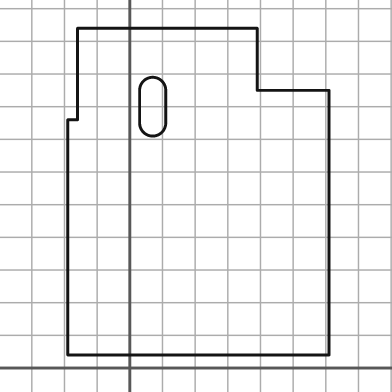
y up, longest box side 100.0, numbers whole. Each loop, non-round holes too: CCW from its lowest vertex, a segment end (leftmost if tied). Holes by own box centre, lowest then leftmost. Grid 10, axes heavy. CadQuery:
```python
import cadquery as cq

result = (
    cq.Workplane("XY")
    .moveTo(-19.0, 4.0)
    .lineTo(61.0, 4.0)
    .lineTo(61.0, 85.0)
    .lineTo(39.0, 85.0)
    .lineTo(39.0, 104.0)
    .lineTo(-16.0, 104.0)
    .lineTo(-16.0, 76.0)
    .lineTo(-19.0, 76.0)
    .close()
    .moveTo(3.0, 75.0)
    .threePointArc((7.0, 71.0), (11.0, 75.0))
    .lineTo(11.0, 85.0)
    .threePointArc((7.0, 89.0), (3.0, 85.0))
    .close()
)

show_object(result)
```